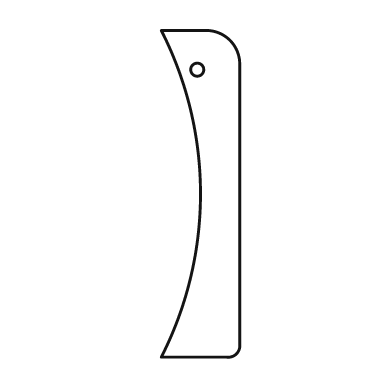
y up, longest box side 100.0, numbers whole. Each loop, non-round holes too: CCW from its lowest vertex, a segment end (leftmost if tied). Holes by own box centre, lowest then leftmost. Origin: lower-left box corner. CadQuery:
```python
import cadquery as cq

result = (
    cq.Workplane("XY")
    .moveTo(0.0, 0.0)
    .lineTo(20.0, 0.0)
    .threePointArc((23.0, 1.0), (24.0, 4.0))
    .lineTo(24.0, 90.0)
    .threePointArc((21.0, 97.0), (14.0, 100.0))
    .lineTo(0.0, 100.0)
    .threePointArc((12.0, 50.0), (0.0, 0.0))
    .close()
    .moveTo(11.0, 88.0)
    .circle(2.0)
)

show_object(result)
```